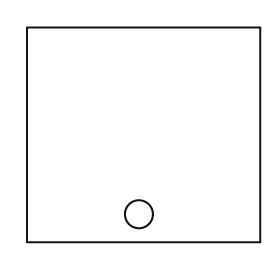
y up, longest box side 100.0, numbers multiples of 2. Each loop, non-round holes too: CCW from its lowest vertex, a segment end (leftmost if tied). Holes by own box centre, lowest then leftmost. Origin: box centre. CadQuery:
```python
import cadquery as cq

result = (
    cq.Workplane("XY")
    .moveTo(-50.0, -46.0)
    .lineTo(50.0, -46.0)
    .lineTo(50.0, 46.0)
    .lineTo(-50.0, 46.0)
    .close()
    .moveTo(-2.0, -34.0)
    .circle(6.0)
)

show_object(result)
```